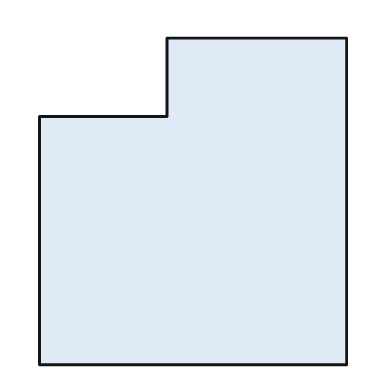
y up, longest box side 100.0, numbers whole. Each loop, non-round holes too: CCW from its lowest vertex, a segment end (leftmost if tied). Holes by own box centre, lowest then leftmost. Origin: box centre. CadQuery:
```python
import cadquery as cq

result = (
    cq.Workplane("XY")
    .moveTo(-47.0, -50.0)
    .lineTo(47.0, -50.0)
    .lineTo(47.0, 50.0)
    .lineTo(-8.0, 50.0)
    .lineTo(-8.0, 26.0)
    .lineTo(-47.0, 26.0)
    .close()
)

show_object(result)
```